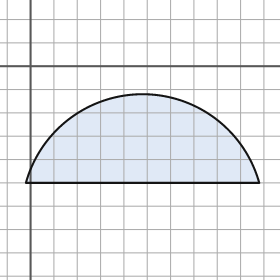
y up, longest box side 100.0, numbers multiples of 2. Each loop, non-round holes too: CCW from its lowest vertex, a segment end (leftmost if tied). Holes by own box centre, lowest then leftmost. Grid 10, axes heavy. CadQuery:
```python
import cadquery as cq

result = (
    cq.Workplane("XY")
    .moveTo(-2.0, -50.0)
    .lineTo(98.0, -50.0)
    .threePointArc((48.0, -12.0), (-2.0, -50.0))
    .close()
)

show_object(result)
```